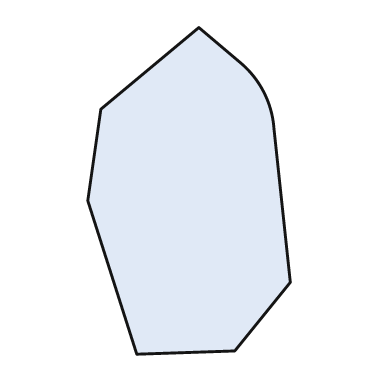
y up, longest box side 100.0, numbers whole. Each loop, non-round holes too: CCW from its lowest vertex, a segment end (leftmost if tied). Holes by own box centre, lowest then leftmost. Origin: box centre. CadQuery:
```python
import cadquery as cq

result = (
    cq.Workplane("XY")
    .moveTo(-16.0, -50.0)
    .lineTo(14.0, -49.0)
    .lineTo(31.0, -28.0)
    .lineTo(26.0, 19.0)
    .threePointArc((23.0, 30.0), (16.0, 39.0))
    .lineTo(3.0, 50.0)
    .lineTo(-27.0, 25.0)
    .lineTo(-31.0, -3.0)
    .close()
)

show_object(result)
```